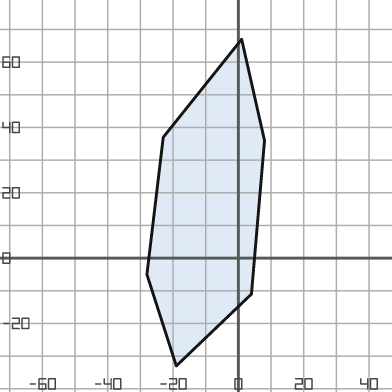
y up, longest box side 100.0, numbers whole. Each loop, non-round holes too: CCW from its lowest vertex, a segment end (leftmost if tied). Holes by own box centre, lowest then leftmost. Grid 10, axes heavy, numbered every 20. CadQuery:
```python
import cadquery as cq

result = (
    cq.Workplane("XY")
    .moveTo(-19.0, -33.0)
    .lineTo(4.0, -11.0)
    .lineTo(8.0, 36.0)
    .lineTo(1.0, 67.0)
    .lineTo(-23.0, 37.0)
    .lineTo(-28.0, -5.0)
    .close()
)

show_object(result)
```